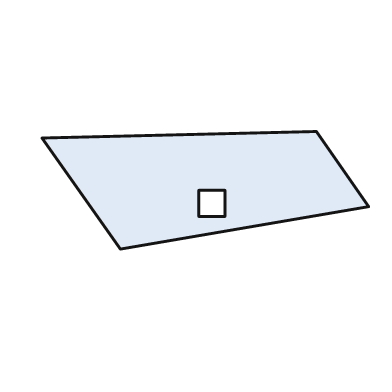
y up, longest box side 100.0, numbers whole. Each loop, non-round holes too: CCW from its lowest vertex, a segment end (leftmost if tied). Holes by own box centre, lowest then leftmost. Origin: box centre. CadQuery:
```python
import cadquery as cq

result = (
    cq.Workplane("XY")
    .moveTo(-26.0, -18.0)
    .lineTo(50.0, -5.0)
    .lineTo(34.0, 18.0)
    .lineTo(-50.0, 16.0)
    .close()
    .moveTo(-2.0, -8.0)
    .lineTo(6.0, -8.0)
    .lineTo(6.0, 0.0)
    .lineTo(-2.0, 0.0)
    .close()
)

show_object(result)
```